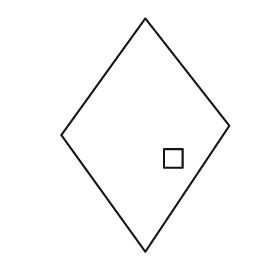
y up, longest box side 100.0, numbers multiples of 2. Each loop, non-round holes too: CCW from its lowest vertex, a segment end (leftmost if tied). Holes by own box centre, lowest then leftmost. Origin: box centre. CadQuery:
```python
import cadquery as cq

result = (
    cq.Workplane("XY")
    .moveTo(0.0, -50.0)
    .lineTo(36.0, 4.0)
    .lineTo(0.0, 50.0)
    .lineTo(-36.0, 0.0)
    .close()
    .moveTo(8.0, -14.0)
    .lineTo(16.0, -14.0)
    .lineTo(16.0, -6.0)
    .lineTo(8.0, -6.0)
    .close()
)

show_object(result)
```